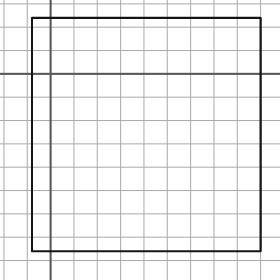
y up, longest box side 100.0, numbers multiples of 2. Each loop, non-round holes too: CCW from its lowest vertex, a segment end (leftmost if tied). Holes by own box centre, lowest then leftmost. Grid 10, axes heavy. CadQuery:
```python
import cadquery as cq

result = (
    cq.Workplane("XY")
    .moveTo(-8.0, -76.0)
    .lineTo(90.0, -76.0)
    .lineTo(90.0, 24.0)
    .lineTo(-8.0, 24.0)
    .close()
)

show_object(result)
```